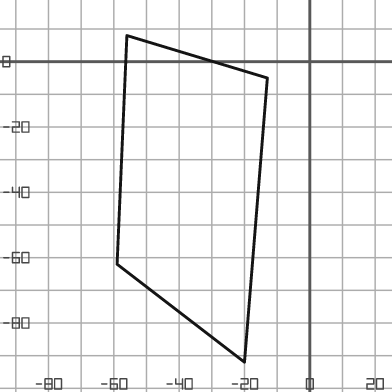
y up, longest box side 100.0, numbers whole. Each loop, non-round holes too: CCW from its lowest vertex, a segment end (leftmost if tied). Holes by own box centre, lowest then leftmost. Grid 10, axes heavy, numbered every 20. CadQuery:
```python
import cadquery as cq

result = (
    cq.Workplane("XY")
    .moveTo(-20.0, -92.0)
    .lineTo(-13.0, -5.0)
    .lineTo(-56.0, 8.0)
    .lineTo(-59.0, -62.0)
    .close()
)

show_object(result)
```